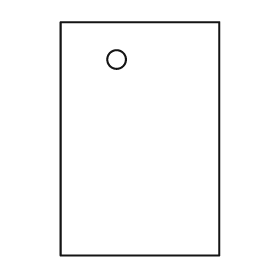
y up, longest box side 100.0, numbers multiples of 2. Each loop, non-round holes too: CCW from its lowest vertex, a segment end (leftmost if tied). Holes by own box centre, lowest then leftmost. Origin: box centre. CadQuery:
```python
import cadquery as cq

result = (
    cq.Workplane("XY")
    .moveTo(-34.0, -50.0)
    .lineTo(34.0, -50.0)
    .lineTo(34.0, 50.0)
    .lineTo(-34.0, 50.0)
    .close()
    .moveTo(-10.0, 34.0)
    .circle(4.0)
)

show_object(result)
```